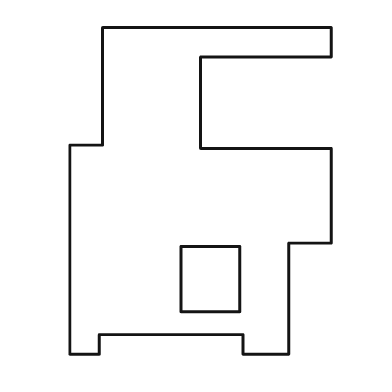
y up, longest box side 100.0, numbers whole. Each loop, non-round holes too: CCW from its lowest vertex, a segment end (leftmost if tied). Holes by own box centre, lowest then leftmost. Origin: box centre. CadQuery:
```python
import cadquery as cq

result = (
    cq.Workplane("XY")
    .moveTo(-40.0, -50.0)
    .lineTo(-31.0, -50.0)
    .lineTo(-31.0, -44.0)
    .lineTo(13.0, -44.0)
    .lineTo(13.0, -50.0)
    .lineTo(27.0, -50.0)
    .lineTo(27.0, -16.0)
    .lineTo(40.0, -16.0)
    .lineTo(40.0, 13.0)
    .lineTo(0.0, 13.0)
    .lineTo(0.0, 41.0)
    .lineTo(40.0, 41.0)
    .lineTo(40.0, 50.0)
    .lineTo(-30.0, 50.0)
    .lineTo(-30.0, 14.0)
    .lineTo(-40.0, 14.0)
    .close()
    .moveTo(-6.0, -37.0)
    .lineTo(12.0, -37.0)
    .lineTo(12.0, -17.0)
    .lineTo(-6.0, -17.0)
    .close()
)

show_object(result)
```